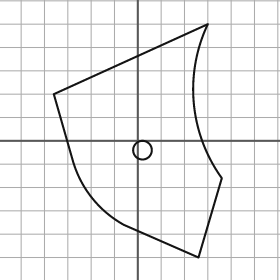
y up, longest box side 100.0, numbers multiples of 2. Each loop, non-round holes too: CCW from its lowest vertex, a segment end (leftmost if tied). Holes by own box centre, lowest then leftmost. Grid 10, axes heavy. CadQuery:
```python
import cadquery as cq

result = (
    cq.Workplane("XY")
    .moveTo(26.0, -50.0)
    .lineTo(36.0, -16.0)
    .threePointArc((24.0, 16.0), (30.0, 50.0))
    .lineTo(-36.0, 20.0)
    .lineTo(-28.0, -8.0)
    .threePointArc((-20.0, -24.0), (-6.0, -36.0))
    .close()
    .moveTo(2.0, -4.0)
    .circle(4.0)
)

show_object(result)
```